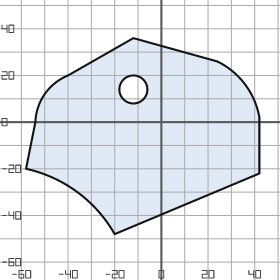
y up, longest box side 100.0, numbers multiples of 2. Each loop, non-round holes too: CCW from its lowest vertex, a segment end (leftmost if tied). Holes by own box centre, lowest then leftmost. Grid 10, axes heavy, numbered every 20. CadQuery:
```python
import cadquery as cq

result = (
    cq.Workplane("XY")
    .moveTo(-20.0, -48.0)
    .lineTo(42.0, -22.0)
    .lineTo(42.0, 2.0)
    .threePointArc((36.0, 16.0), (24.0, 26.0))
    .lineTo(-12.0, 36.0)
    .lineTo(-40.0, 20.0)
    .threePointArc((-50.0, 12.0), (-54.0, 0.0))
    .lineTo(-58.0, -20.0)
    .threePointArc((-36.0, -30.0), (-20.0, -48.0))
    .close()
    .moveTo(-12.0, 14.0)
    .circle(6.0)
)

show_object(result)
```